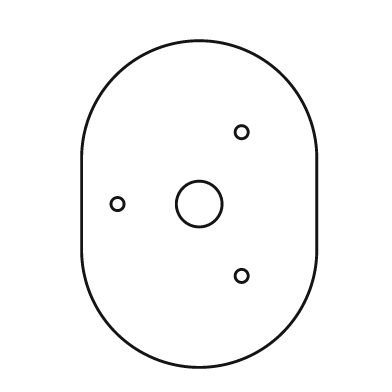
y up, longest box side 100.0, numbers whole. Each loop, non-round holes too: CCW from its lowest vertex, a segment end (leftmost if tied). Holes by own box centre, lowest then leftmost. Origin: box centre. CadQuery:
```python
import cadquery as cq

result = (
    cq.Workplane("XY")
    .moveTo(-36.0, -14.0)
    .threePointArc((0.0, -50.0), (36.0, -14.0))
    .lineTo(36.0, 14.0)
    .threePointArc((0.0, 50.0), (-36.0, 14.0))
    .close()
    .moveTo(13.0, -22.0)
    .circle(2.0)
    .moveTo(-25.0, 0.0)
    .circle(2.0)
    .moveTo(0.0, 0.0)
    .circle(7.0)
    .moveTo(13.0, 22.0)
    .circle(2.0)
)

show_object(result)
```